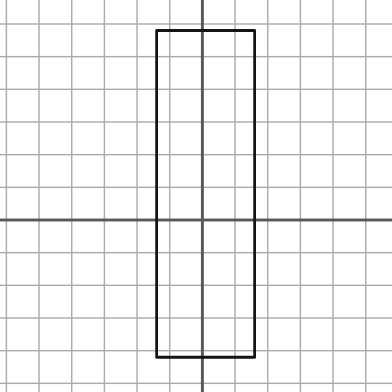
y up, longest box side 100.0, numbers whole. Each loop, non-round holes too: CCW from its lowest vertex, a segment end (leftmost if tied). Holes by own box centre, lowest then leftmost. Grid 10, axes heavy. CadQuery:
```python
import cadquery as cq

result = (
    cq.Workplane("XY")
    .moveTo(-14.0, -42.0)
    .lineTo(16.0, -42.0)
    .lineTo(16.0, 58.0)
    .lineTo(-14.0, 58.0)
    .close()
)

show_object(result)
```